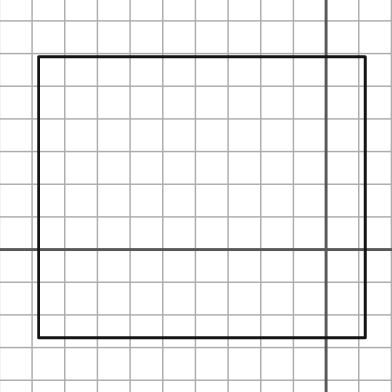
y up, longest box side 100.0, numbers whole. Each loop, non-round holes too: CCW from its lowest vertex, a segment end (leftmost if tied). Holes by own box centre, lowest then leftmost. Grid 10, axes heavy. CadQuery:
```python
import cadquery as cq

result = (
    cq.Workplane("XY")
    .moveTo(-88.0, -27.0)
    .lineTo(12.0, -27.0)
    .lineTo(12.0, 59.0)
    .lineTo(-88.0, 59.0)
    .close()
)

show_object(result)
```